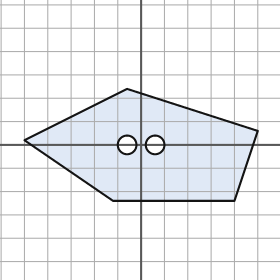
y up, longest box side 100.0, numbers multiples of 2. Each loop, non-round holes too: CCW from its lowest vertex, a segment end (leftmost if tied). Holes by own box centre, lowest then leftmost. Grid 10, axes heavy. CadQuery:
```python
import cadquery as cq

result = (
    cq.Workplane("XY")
    .moveTo(-12.0, -24.0)
    .lineTo(40.0, -24.0)
    .lineTo(50.0, 6.0)
    .lineTo(-6.0, 24.0)
    .lineTo(-50.0, 2.0)
    .close()
    .moveTo(-6.0, 0.0)
    .circle(4.0)
    .moveTo(6.0, 0.0)
    .circle(4.0)
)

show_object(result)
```